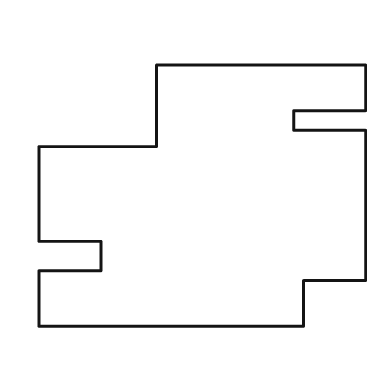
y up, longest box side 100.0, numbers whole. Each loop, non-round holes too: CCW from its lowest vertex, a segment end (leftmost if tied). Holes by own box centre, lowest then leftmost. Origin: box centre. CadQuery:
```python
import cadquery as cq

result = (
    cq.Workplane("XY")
    .moveTo(-50.0, -40.0)
    .lineTo(31.0, -40.0)
    .lineTo(31.0, -26.0)
    .lineTo(50.0, -26.0)
    .lineTo(50.0, 20.0)
    .lineTo(28.0, 20.0)
    .lineTo(28.0, 26.0)
    .lineTo(50.0, 26.0)
    .lineTo(50.0, 40.0)
    .lineTo(-14.0, 40.0)
    .lineTo(-14.0, 15.0)
    .lineTo(-50.0, 15.0)
    .lineTo(-50.0, -14.0)
    .lineTo(-31.0, -14.0)
    .lineTo(-31.0, -23.0)
    .lineTo(-50.0, -23.0)
    .close()
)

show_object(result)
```